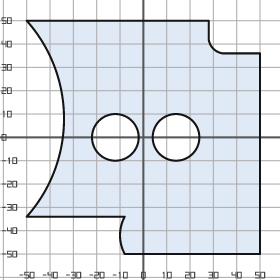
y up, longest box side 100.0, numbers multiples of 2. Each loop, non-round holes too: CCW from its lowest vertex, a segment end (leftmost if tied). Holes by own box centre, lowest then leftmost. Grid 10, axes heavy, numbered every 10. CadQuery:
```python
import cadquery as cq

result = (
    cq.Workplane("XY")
    .moveTo(-8.0, -50.0)
    .lineTo(50.0, -50.0)
    .lineTo(50.0, 36.0)
    .lineTo(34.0, 36.0)
    .threePointArc((30.0, 38.0), (28.0, 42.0))
    .lineTo(28.0, 50.0)
    .lineTo(-50.0, 50.0)
    .threePointArc((-34.0, 8.0), (-50.0, -34.0))
    .lineTo(-8.0, -34.0)
    .threePointArc((-10.0, -42.0), (-8.0, -50.0))
    .close()
    .moveTo(-12.0, 0.0)
    .circle(10.0)
    .moveTo(14.0, 0.0)
    .circle(10.0)
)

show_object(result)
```